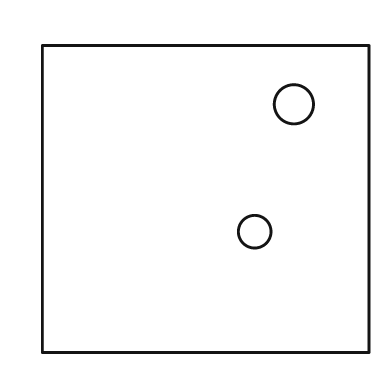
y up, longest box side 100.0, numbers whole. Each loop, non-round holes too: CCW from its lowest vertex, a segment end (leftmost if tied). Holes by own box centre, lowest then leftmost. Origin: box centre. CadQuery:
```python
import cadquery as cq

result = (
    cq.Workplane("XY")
    .moveTo(-50.0, -47.0)
    .lineTo(50.0, -47.0)
    .lineTo(50.0, 47.0)
    .lineTo(-50.0, 47.0)
    .close()
    .moveTo(15.0, -10.0)
    .circle(5.0)
    .moveTo(27.0, 29.0)
    .circle(6.0)
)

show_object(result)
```